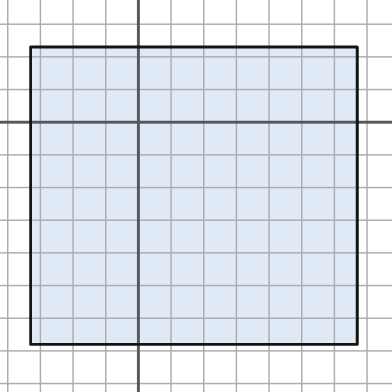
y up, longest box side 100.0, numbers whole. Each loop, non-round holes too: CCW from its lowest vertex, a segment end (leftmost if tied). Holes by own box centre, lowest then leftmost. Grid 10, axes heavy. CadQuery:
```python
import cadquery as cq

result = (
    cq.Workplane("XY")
    .moveTo(-33.0, -68.0)
    .lineTo(67.0, -68.0)
    .lineTo(67.0, 23.0)
    .lineTo(-33.0, 23.0)
    .close()
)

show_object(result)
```